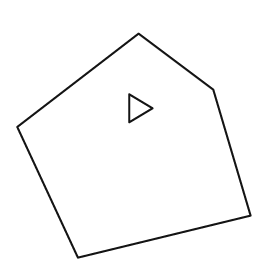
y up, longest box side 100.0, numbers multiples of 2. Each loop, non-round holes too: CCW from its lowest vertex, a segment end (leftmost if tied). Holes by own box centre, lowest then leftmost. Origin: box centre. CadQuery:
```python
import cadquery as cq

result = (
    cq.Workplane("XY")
    .moveTo(-24.0, -48.0)
    .lineTo(50.0, -30.0)
    .lineTo(34.0, 24.0)
    .lineTo(2.0, 48.0)
    .lineTo(-50.0, 8.0)
    .close()
    .moveTo(-2.0, 10.0)
    .lineTo(8.0, 16.0)
    .lineTo(-2.0, 22.0)
    .close()
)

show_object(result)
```